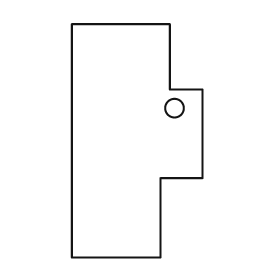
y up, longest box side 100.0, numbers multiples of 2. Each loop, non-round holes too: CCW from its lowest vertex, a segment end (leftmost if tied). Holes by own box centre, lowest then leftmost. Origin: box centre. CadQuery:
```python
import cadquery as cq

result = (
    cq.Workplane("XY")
    .moveTo(-28.0, -50.0)
    .lineTo(10.0, -50.0)
    .lineTo(10.0, -16.0)
    .lineTo(28.0, -16.0)
    .lineTo(28.0, 22.0)
    .lineTo(14.0, 22.0)
    .lineTo(14.0, 50.0)
    .lineTo(-28.0, 50.0)
    .close()
    .moveTo(16.0, 14.0)
    .circle(4.0)
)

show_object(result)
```